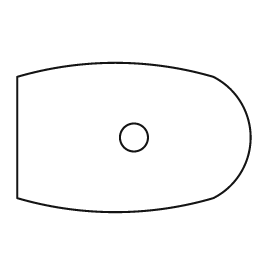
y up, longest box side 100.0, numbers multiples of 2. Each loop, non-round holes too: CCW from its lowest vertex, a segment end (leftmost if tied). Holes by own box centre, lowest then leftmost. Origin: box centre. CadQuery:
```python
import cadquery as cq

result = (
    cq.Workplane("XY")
    .moveTo(-50.0, -26.0)
    .threePointArc((-8.0, -32.0), (34.0, -26.0))
    .threePointArc((50.0, 0.0), (34.0, 26.0))
    .threePointArc((-8.0, 32.0), (-50.0, 26.0))
    .close()
    .moveTo(0.0, 0.0)
    .circle(6.0)
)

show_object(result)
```